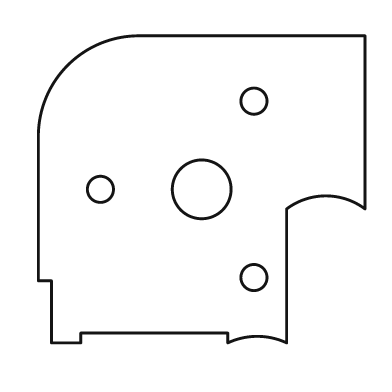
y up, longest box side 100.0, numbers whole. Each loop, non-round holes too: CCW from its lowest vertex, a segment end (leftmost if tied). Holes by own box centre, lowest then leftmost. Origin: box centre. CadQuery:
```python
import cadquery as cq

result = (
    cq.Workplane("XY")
    .moveTo(-46.0, -47.0)
    .lineTo(-37.0, -47.0)
    .lineTo(-37.0, -44.0)
    .lineTo(8.0, -44.0)
    .lineTo(8.0, -47.0)
    .threePointArc((17.0, -45.0), (26.0, -47.0))
    .lineTo(26.0, -6.0)
    .threePointArc((38.0, -2.0), (50.0, -6.0))
    .lineTo(50.0, 47.0)
    .lineTo(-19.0, 47.0)
    .threePointArc((-41.0, 38.0), (-50.0, 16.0))
    .lineTo(-50.0, -28.0)
    .lineTo(-46.0, -28.0)
    .close()
    .moveTo(16.0, -27.0)
    .circle(4.0)
    .moveTo(-31.0, 0.0)
    .circle(4.0)
    .moveTo(0.0, 0.0)
    .circle(9.0)
    .moveTo(16.0, 27.0)
    .circle(4.0)
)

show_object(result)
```